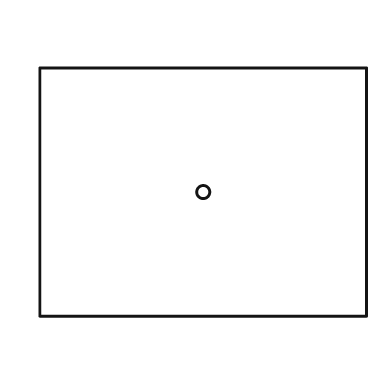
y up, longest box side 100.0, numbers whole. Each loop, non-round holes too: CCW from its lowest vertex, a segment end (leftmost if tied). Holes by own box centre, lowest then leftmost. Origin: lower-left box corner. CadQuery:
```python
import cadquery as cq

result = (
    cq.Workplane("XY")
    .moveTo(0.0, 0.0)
    .lineTo(100.0, 0.0)
    .lineTo(100.0, 76.0)
    .lineTo(0.0, 76.0)
    .close()
    .moveTo(50.0, 38.0)
    .circle(2.0)
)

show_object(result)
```